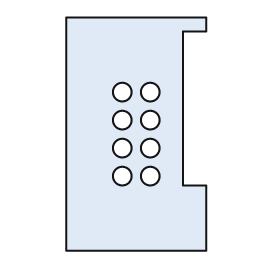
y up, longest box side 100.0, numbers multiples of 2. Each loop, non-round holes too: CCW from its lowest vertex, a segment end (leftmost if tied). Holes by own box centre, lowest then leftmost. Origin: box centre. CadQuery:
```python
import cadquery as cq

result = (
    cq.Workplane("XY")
    .moveTo(-30.0, -50.0)
    .lineTo(30.0, -50.0)
    .lineTo(30.0, -22.0)
    .lineTo(20.0, -22.0)
    .lineTo(20.0, 44.0)
    .lineTo(30.0, 44.0)
    .lineTo(30.0, 50.0)
    .lineTo(-30.0, 50.0)
    .close()
    .moveTo(-6.0, -18.0)
    .circle(4.0)
    .moveTo(6.0, -18.0)
    .circle(4.0)
    .moveTo(-6.0, -6.0)
    .circle(4.0)
    .moveTo(6.0, -6.0)
    .circle(4.0)
    .moveTo(-6.0, 6.0)
    .circle(4.0)
    .moveTo(6.0, 6.0)
    .circle(4.0)
    .moveTo(-6.0, 18.0)
    .circle(4.0)
    .moveTo(6.0, 18.0)
    .circle(4.0)
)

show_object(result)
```